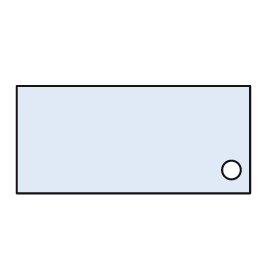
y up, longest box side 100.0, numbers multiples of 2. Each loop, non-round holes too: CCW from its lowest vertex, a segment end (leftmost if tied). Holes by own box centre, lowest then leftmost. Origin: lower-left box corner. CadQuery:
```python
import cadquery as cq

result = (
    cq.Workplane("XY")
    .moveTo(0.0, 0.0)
    .lineTo(100.0, 0.0)
    .lineTo(100.0, 46.0)
    .lineTo(0.0, 46.0)
    .close()
    .moveTo(92.0, 10.0)
    .circle(4.0)
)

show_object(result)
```